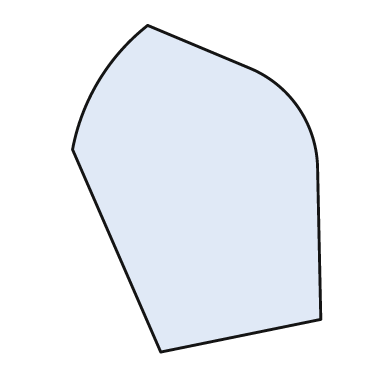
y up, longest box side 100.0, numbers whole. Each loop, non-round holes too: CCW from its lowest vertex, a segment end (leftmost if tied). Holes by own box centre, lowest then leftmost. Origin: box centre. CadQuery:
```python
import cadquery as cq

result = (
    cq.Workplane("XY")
    .moveTo(-11.0, -50.0)
    .lineTo(38.0, -40.0)
    .lineTo(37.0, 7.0)
    .threePointArc((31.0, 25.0), (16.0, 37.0))
    .lineTo(-15.0, 50.0)
    .threePointArc((-30.0, 33.0), (-38.0, 12.0))
    .close()
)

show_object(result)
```